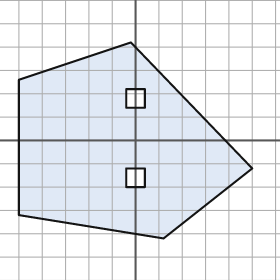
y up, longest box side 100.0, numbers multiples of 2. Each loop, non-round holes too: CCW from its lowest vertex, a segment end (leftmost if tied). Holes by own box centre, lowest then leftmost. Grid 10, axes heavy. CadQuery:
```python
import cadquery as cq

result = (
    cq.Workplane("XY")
    .moveTo(12.0, -42.0)
    .lineTo(50.0, -12.0)
    .lineTo(-2.0, 42.0)
    .lineTo(-50.0, 26.0)
    .lineTo(-50.0, -32.0)
    .close()
    .moveTo(-4.0, -20.0)
    .lineTo(4.0, -20.0)
    .lineTo(4.0, -12.0)
    .lineTo(-4.0, -12.0)
    .close()
    .moveTo(-4.0, 14.0)
    .lineTo(4.0, 14.0)
    .lineTo(4.0, 22.0)
    .lineTo(-4.0, 22.0)
    .close()
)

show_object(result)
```